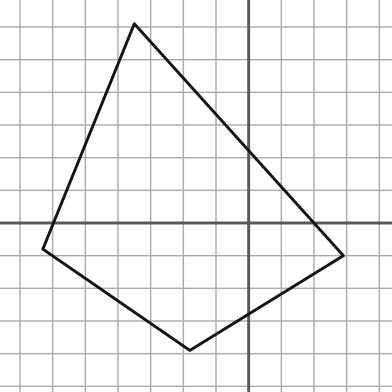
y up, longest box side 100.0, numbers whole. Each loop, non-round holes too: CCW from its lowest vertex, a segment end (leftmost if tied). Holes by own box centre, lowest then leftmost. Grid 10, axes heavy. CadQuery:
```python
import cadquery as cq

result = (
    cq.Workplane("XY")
    .moveTo(-18.0, -39.0)
    .lineTo(29.0, -10.0)
    .lineTo(-35.0, 61.0)
    .lineTo(-63.0, -8.0)
    .close()
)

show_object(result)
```